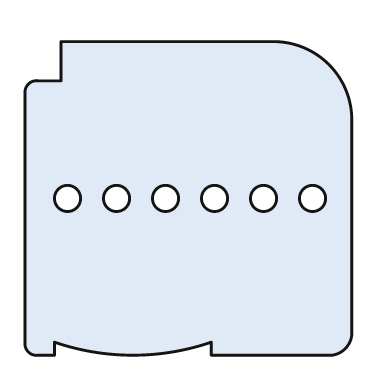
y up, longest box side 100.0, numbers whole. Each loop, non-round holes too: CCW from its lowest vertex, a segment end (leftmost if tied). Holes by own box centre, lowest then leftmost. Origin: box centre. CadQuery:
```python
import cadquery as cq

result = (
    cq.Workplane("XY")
    .moveTo(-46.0, -48.0)
    .lineTo(-41.0, -48.0)
    .lineTo(-41.0, -44.0)
    .threePointArc((-17.0, -48.0), (7.0, -44.0))
    .lineTo(7.0, -48.0)
    .lineTo(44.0, -48.0)
    .threePointArc((48.0, -46.0), (50.0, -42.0))
    .lineTo(50.0, 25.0)
    .threePointArc((43.0, 41.0), (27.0, 48.0))
    .lineTo(-39.0, 48.0)
    .lineTo(-39.0, 36.0)
    .lineTo(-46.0, 36.0)
    .threePointArc((-49.0, 35.0), (-50.0, 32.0))
    .lineTo(-50.0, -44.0)
    .threePointArc((-49.0, -47.0), (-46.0, -48.0))
    .close()
    .moveTo(-37.0, 0.0)
    .circle(4.0)
    .moveTo(-22.0, 0.0)
    .circle(4.0)
    .moveTo(-7.0, 0.0)
    .circle(4.0)
    .moveTo(8.0, 0.0)
    .circle(4.0)
    .moveTo(23.0, 0.0)
    .circle(4.0)
    .moveTo(38.0, 0.0)
    .circle(4.0)
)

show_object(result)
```